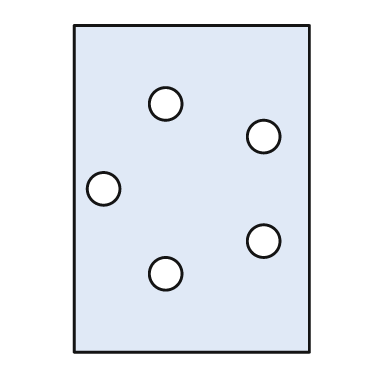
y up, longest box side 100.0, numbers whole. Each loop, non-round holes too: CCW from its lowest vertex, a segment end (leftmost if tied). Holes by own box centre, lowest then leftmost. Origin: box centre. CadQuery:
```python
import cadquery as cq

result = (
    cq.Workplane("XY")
    .moveTo(-36.0, -50.0)
    .lineTo(36.0, -50.0)
    .lineTo(36.0, 50.0)
    .lineTo(-36.0, 50.0)
    .close()
    .moveTo(-8.0, -26.0)
    .circle(5.0)
    .moveTo(22.0, -16.0)
    .circle(5.0)
    .moveTo(-27.0, 0.0)
    .circle(5.0)
    .moveTo(22.0, 16.0)
    .circle(5.0)
    .moveTo(-8.0, 26.0)
    .circle(5.0)
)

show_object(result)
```